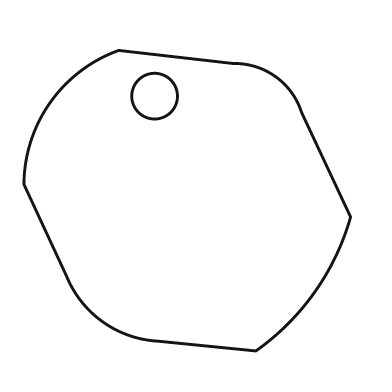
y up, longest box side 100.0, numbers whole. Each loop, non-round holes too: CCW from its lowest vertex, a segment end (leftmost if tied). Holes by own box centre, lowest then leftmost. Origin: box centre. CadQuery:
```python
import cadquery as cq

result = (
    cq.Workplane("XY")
    .moveTo(21.0, -46.0)
    .threePointArc((39.0, -28.0), (50.0, -5.0))
    .lineTo(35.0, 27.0)
    .threePointArc((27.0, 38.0), (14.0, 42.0))
    .lineTo(-21.0, 46.0)
    .threePointArc((-42.0, 30.0), (-50.0, 5.0))
    .lineTo(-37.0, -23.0)
    .threePointArc((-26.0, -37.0), (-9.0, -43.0))
    .close()
    .moveTo(-10.0, 32.0)
    .circle(7.0)
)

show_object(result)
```